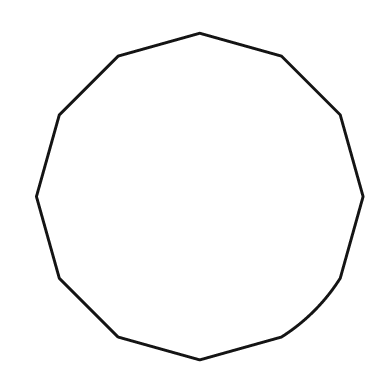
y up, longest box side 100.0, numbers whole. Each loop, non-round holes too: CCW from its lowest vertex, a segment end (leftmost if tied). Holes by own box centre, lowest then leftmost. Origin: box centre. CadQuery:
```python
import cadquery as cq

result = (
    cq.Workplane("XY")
    .moveTo(0.0, -50.0)
    .lineTo(25.0, -43.0)
    .threePointArc((35.0, -35.0), (43.0, -25.0))
    .lineTo(50.0, 0.0)
    .lineTo(43.0, 25.0)
    .lineTo(25.0, 43.0)
    .lineTo(0.0, 50.0)
    .lineTo(-25.0, 43.0)
    .lineTo(-43.0, 25.0)
    .lineTo(-50.0, 0.0)
    .lineTo(-43.0, -25.0)
    .lineTo(-25.0, -43.0)
    .close()
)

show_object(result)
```